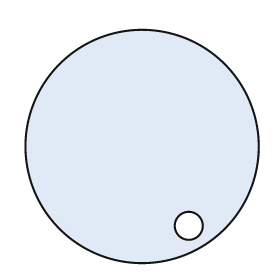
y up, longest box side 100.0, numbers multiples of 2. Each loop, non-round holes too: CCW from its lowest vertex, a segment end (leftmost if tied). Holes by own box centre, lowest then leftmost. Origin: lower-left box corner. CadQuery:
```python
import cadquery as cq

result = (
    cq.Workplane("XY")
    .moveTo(50.0, 50.0)
    .circle(50.0)
    .moveTo(70.0, 16.0)
    .circle(6.0)
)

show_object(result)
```